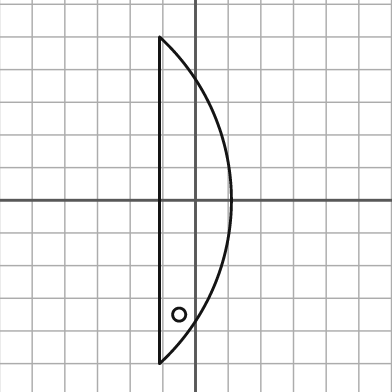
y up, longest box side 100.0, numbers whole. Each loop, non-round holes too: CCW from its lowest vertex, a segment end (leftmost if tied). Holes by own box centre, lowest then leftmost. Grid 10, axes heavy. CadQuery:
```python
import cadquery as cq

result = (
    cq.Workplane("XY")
    .moveTo(-11.0, -50.0)
    .threePointArc((11.0, 0.0), (-11.0, 50.0))
    .close()
    .moveTo(-5.0, -35.0)
    .circle(2.0)
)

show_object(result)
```